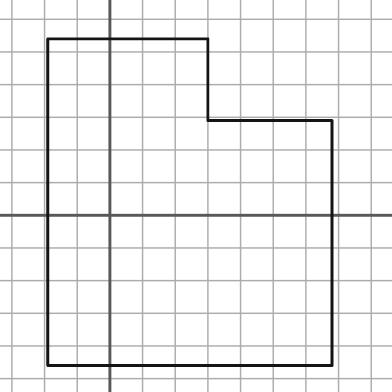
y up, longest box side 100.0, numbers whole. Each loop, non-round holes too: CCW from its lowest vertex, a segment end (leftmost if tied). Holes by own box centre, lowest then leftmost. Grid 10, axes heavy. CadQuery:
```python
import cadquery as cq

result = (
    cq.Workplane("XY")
    .moveTo(-19.0, -46.0)
    .lineTo(68.0, -46.0)
    .lineTo(68.0, 29.0)
    .lineTo(30.0, 29.0)
    .lineTo(30.0, 54.0)
    .lineTo(-19.0, 54.0)
    .close()
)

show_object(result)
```